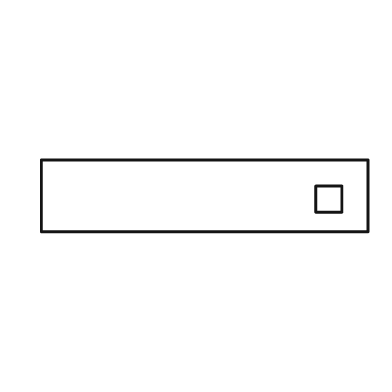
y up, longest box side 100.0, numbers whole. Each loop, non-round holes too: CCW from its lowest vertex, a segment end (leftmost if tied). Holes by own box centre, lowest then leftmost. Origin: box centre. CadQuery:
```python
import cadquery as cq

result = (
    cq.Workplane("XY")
    .moveTo(-50.0, -11.0)
    .lineTo(50.0, -11.0)
    .lineTo(50.0, 11.0)
    .lineTo(-50.0, 11.0)
    .close()
    .moveTo(34.0, -5.0)
    .lineTo(42.0, -5.0)
    .lineTo(42.0, 3.0)
    .lineTo(34.0, 3.0)
    .close()
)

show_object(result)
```